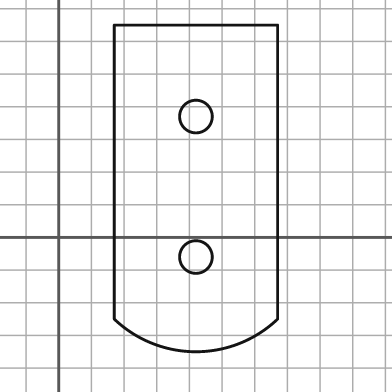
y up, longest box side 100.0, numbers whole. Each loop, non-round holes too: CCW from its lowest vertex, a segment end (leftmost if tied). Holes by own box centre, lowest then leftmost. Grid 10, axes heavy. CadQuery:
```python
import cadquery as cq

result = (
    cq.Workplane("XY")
    .moveTo(17.0, -25.0)
    .threePointArc((42.0, -35.0), (67.0, -25.0))
    .lineTo(67.0, 65.0)
    .lineTo(17.0, 65.0)
    .close()
    .moveTo(42.0, -6.0)
    .circle(5.0)
    .moveTo(42.0, 37.0)
    .circle(5.0)
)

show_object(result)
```